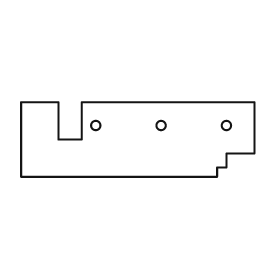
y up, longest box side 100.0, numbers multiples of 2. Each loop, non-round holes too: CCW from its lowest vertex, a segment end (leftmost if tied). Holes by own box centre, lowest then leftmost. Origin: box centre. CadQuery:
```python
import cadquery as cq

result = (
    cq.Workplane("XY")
    .moveTo(-50.0, -16.0)
    .lineTo(34.0, -16.0)
    .lineTo(34.0, -12.0)
    .lineTo(38.0, -12.0)
    .lineTo(38.0, -6.0)
    .lineTo(50.0, -6.0)
    .lineTo(50.0, 16.0)
    .lineTo(-24.0, 16.0)
    .lineTo(-24.0, 0.0)
    .lineTo(-34.0, 0.0)
    .lineTo(-34.0, 16.0)
    .lineTo(-50.0, 16.0)
    .close()
    .moveTo(-18.0, 6.0)
    .circle(2.0)
    .moveTo(10.0, 6.0)
    .circle(2.0)
    .moveTo(38.0, 6.0)
    .circle(2.0)
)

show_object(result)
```